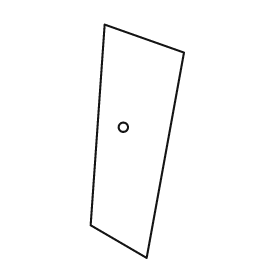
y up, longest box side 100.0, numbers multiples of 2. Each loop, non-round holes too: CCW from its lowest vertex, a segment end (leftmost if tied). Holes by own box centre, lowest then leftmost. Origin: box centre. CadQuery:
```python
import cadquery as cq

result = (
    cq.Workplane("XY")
    .moveTo(4.0, -50.0)
    .lineTo(20.0, 38.0)
    .lineTo(-14.0, 50.0)
    .lineTo(-20.0, -36.0)
    .close()
    .moveTo(-6.0, 6.0)
    .circle(2.0)
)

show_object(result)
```